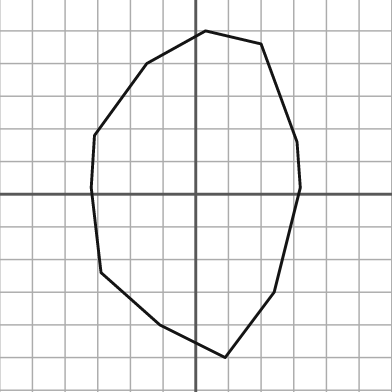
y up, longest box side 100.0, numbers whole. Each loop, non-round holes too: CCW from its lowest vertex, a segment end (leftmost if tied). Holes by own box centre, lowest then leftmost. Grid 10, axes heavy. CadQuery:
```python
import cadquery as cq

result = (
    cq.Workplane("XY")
    .moveTo(9.0, -50.0)
    .lineTo(24.0, -30.0)
    .lineTo(32.0, 2.0)
    .lineTo(31.0, 16.0)
    .lineTo(20.0, 46.0)
    .lineTo(3.0, 50.0)
    .lineTo(-15.0, 40.0)
    .lineTo(-31.0, 18.0)
    .lineTo(-32.0, 2.0)
    .lineTo(-29.0, -24.0)
    .lineTo(-11.0, -40.0)
    .close()
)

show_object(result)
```